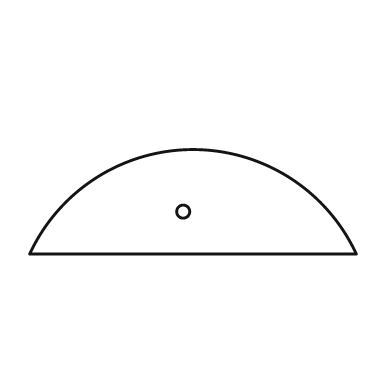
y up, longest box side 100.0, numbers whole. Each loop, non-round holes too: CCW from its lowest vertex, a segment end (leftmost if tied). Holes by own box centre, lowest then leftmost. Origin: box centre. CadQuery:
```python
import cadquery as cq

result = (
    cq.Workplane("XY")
    .moveTo(-50.0, -16.0)
    .lineTo(50.0, -16.0)
    .threePointArc((0.0, 16.0), (-50.0, -16.0))
    .close()
    .moveTo(-3.0, -3.0)
    .circle(2.0)
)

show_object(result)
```